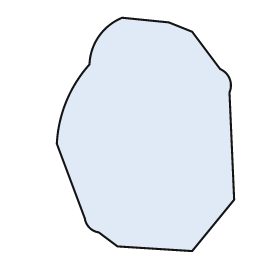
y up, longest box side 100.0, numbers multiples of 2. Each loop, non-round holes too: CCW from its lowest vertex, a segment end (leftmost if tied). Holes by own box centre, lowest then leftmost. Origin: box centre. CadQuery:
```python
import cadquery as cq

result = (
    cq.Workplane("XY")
    .moveTo(20.0, -50.0)
    .lineTo(38.0, -28.0)
    .lineTo(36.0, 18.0)
    .threePointArc((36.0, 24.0), (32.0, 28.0))
    .lineTo(20.0, 44.0)
    .lineTo(10.0, 48.0)
    .lineTo(-10.0, 50.0)
    .threePointArc((-20.0, 42.0), (-24.0, 30.0))
    .threePointArc((-34.0, 14.0), (-38.0, -4.0))
    .lineTo(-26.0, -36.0)
    .threePointArc((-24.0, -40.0), (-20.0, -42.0))
    .lineTo(-12.0, -48.0)
    .close()
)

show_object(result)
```